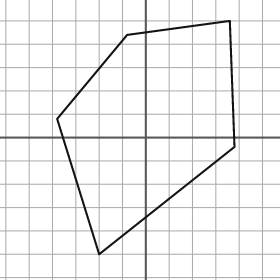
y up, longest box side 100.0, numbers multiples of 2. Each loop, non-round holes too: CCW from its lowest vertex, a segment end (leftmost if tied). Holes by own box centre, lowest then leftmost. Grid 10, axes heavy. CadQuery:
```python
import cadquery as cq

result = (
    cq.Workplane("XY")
    .moveTo(-20.0, -50.0)
    .lineTo(38.0, -4.0)
    .lineTo(36.0, 50.0)
    .lineTo(-8.0, 44.0)
    .lineTo(-38.0, 8.0)
    .close()
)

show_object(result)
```